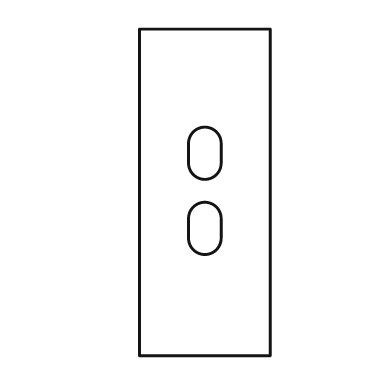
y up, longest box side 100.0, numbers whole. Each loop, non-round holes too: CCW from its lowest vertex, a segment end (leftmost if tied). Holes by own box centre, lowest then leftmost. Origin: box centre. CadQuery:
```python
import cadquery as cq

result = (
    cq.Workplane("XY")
    .moveTo(-20.0, -50.0)
    .lineTo(20.0, -50.0)
    .lineTo(20.0, 50.0)
    .lineTo(-20.0, 50.0)
    .close()
    .moveTo(-5.0, -14.0)
    .threePointArc((0.0, -19.0), (5.0, -14.0))
    .lineTo(5.0, -8.0)
    .threePointArc((0.0, -3.0), (-5.0, -8.0))
    .close()
    .moveTo(-5.0, 9.0)
    .threePointArc((0.0, 4.0), (5.0, 9.0))
    .lineTo(5.0, 15.0)
    .threePointArc((0.0, 20.0), (-5.0, 15.0))
    .close()
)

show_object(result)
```